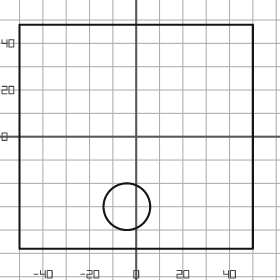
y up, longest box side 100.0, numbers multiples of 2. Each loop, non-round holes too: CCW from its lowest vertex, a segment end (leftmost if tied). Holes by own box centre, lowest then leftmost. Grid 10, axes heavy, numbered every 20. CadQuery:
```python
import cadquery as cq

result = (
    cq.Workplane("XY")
    .moveTo(-50.0, -48.0)
    .lineTo(50.0, -48.0)
    .lineTo(50.0, 48.0)
    .lineTo(-50.0, 48.0)
    .close()
    .moveTo(-4.0, -30.0)
    .circle(10.0)
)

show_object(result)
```